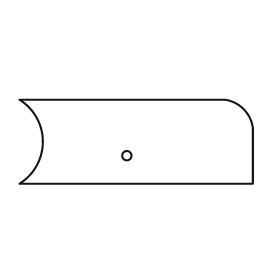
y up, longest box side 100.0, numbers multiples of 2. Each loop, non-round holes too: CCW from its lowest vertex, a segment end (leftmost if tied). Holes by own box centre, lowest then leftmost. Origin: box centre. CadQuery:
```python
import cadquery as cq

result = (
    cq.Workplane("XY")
    .moveTo(-50.0, -18.0)
    .lineTo(50.0, -18.0)
    .lineTo(50.0, 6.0)
    .threePointArc((46.0, 14.0), (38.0, 18.0))
    .lineTo(-50.0, 18.0)
    .threePointArc((-40.0, 0.0), (-50.0, -18.0))
    .close()
    .moveTo(-4.0, -6.0)
    .circle(2.0)
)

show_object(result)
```